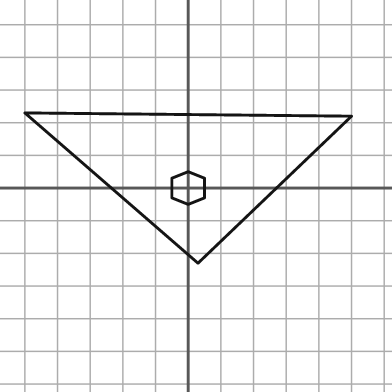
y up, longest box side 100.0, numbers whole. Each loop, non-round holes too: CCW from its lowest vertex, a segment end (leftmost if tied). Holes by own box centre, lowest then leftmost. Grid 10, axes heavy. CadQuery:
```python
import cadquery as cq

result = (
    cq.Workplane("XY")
    .moveTo(3.0, -23.0)
    .lineTo(50.0, 22.0)
    .lineTo(-50.0, 23.0)
    .close()
    .moveTo(0.0, -5.0)
    .lineTo(5.0, -3.0)
    .lineTo(5.0, 3.0)
    .lineTo(0.0, 5.0)
    .lineTo(-5.0, 3.0)
    .lineTo(-5.0, -3.0)
    .close()
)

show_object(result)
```